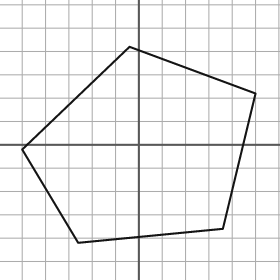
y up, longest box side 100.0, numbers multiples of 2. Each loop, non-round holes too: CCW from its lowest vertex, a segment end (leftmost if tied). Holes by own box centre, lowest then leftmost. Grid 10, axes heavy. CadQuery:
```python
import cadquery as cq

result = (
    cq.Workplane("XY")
    .moveTo(-26.0, -42.0)
    .lineTo(36.0, -36.0)
    .lineTo(50.0, 22.0)
    .lineTo(-4.0, 42.0)
    .lineTo(-50.0, -2.0)
    .close()
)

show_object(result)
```